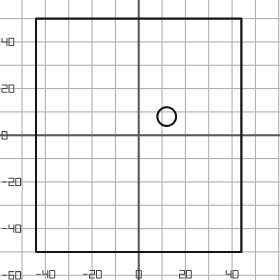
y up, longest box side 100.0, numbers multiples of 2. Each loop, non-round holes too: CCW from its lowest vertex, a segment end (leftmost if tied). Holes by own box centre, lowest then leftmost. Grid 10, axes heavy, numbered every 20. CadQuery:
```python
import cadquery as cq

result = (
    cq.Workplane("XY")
    .moveTo(-44.0, -50.0)
    .lineTo(44.0, -50.0)
    .lineTo(44.0, 50.0)
    .lineTo(-44.0, 50.0)
    .close()
    .moveTo(12.0, 8.0)
    .circle(4.0)
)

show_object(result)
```